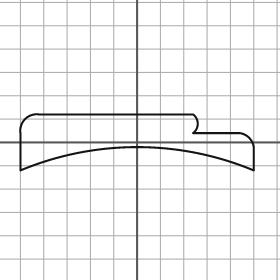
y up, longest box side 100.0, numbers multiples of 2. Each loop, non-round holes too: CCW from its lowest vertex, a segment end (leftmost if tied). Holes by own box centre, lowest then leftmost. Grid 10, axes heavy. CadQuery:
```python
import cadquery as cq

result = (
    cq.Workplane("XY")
    .moveTo(-50.0, -12.0)
    .threePointArc((0.0, -2.0), (50.0, -12.0))
    .lineTo(50.0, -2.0)
    .threePointArc((48.0, 2.0), (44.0, 4.0))
    .lineTo(24.0, 4.0)
    .threePointArc((26.0, 8.0), (24.0, 12.0))
    .lineTo(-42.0, 12.0)
    .threePointArc((-48.0, 10.0), (-50.0, 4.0))
    .close()
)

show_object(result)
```